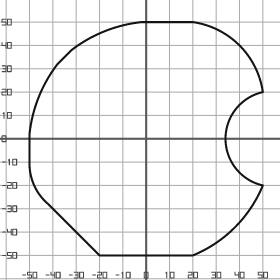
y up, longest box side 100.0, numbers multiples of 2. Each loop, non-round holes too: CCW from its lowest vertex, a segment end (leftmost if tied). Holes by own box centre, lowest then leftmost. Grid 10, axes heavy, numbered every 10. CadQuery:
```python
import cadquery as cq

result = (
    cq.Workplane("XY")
    .moveTo(-20.0, -50.0)
    .lineTo(20.0, -50.0)
    .threePointArc((38.0, -38.0), (50.0, -20.0))
    .threePointArc((34.0, 0.0), (50.0, 20.0))
    .threePointArc((40.0, 40.0), (20.0, 50.0))
    .lineTo(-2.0, 50.0)
    .threePointArc((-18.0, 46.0), (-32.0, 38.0))
    .lineTo(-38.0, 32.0)
    .threePointArc((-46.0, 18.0), (-50.0, 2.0))
    .lineTo(-50.0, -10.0)
    .threePointArc((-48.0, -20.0), (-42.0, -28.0))
    .close()
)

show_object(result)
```